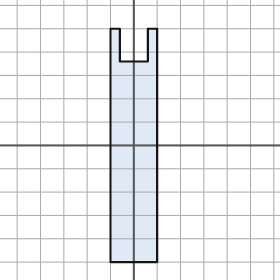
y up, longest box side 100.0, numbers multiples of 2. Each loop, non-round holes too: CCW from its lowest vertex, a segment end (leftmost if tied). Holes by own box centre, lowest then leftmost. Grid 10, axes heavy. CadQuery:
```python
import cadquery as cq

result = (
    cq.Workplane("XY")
    .moveTo(-10.0, -50.0)
    .lineTo(10.0, -50.0)
    .lineTo(10.0, 50.0)
    .lineTo(6.0, 50.0)
    .lineTo(6.0, 36.0)
    .lineTo(-6.0, 36.0)
    .lineTo(-6.0, 50.0)
    .lineTo(-10.0, 50.0)
    .close()
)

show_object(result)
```